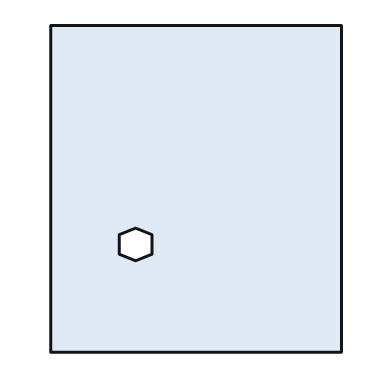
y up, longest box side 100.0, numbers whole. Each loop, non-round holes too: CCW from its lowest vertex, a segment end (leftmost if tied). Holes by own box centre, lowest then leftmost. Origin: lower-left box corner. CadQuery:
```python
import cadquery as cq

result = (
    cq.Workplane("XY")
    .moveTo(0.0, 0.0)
    .lineTo(89.0, 0.0)
    .lineTo(89.0, 100.0)
    .lineTo(0.0, 100.0)
    .close()
    .moveTo(26.0, 28.0)
    .lineTo(31.0, 30.0)
    .lineTo(31.0, 36.0)
    .lineTo(26.0, 38.0)
    .lineTo(21.0, 36.0)
    .lineTo(21.0, 30.0)
    .close()
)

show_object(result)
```